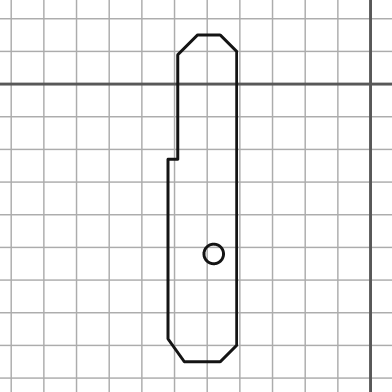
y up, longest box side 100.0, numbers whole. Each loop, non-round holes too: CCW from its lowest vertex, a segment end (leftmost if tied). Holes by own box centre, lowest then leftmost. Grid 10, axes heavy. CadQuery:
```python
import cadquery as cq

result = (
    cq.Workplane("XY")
    .moveTo(-57.0, -85.0)
    .lineTo(-46.0, -85.0)
    .lineTo(-41.0, -80.0)
    .lineTo(-41.0, 10.0)
    .lineTo(-46.0, 15.0)
    .lineTo(-53.0, 15.0)
    .lineTo(-59.0, 9.0)
    .lineTo(-59.0, -23.0)
    .lineTo(-62.0, -23.0)
    .lineTo(-62.0, -78.0)
    .close()
    .moveTo(-48.0, -52.0)
    .circle(3.0)
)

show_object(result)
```